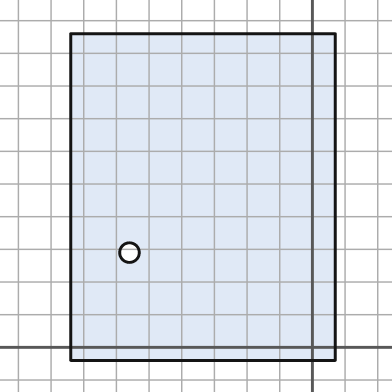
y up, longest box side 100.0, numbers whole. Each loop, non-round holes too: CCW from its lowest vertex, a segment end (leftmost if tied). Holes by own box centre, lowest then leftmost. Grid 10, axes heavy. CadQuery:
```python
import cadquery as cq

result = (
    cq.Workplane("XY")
    .moveTo(-74.0, -4.0)
    .lineTo(7.0, -4.0)
    .lineTo(7.0, 96.0)
    .lineTo(-74.0, 96.0)
    .close()
    .moveTo(-56.0, 29.0)
    .circle(3.0)
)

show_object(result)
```